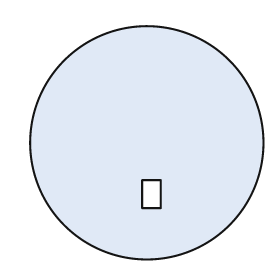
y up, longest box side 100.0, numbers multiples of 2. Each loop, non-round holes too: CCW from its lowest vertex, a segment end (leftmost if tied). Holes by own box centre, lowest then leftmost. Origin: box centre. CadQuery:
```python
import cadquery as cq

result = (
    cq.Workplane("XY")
    .moveTo(0.0, 0.0)
    .circle(50.0)
    .moveTo(-2.0, -28.0)
    .lineTo(6.0, -28.0)
    .lineTo(6.0, -16.0)
    .lineTo(-2.0, -16.0)
    .close()
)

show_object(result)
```